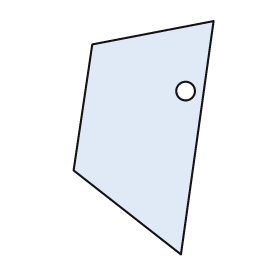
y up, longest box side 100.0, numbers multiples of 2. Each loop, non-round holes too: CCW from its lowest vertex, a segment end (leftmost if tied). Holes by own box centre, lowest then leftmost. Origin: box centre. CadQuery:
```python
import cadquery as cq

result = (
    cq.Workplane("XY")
    .moveTo(16.0, -50.0)
    .lineTo(30.0, 50.0)
    .lineTo(-22.0, 40.0)
    .lineTo(-30.0, -14.0)
    .close()
    .moveTo(18.0, 20.0)
    .circle(4.0)
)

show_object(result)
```